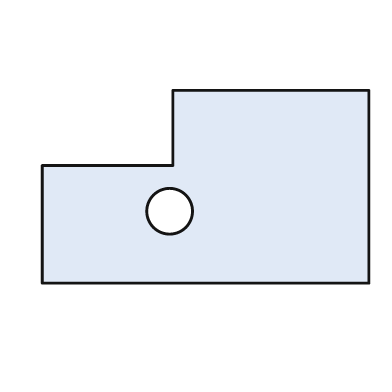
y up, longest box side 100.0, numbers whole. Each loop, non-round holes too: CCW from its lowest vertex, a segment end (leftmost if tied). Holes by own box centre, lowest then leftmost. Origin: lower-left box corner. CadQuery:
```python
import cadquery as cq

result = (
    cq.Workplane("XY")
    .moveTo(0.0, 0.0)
    .lineTo(100.0, 0.0)
    .lineTo(100.0, 59.0)
    .lineTo(40.0, 59.0)
    .lineTo(40.0, 36.0)
    .lineTo(0.0, 36.0)
    .close()
    .moveTo(39.0, 22.0)
    .circle(7.0)
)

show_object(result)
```